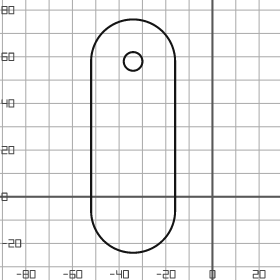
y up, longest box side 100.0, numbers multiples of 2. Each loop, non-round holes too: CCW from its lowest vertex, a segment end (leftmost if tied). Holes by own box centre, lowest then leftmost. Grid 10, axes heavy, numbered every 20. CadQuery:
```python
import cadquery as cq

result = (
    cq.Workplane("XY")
    .moveTo(-52.0, -6.0)
    .threePointArc((-34.0, -24.0), (-16.0, -6.0))
    .lineTo(-16.0, 58.0)
    .threePointArc((-34.0, 76.0), (-52.0, 58.0))
    .close()
    .moveTo(-34.0, 58.0)
    .circle(4.0)
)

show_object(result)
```